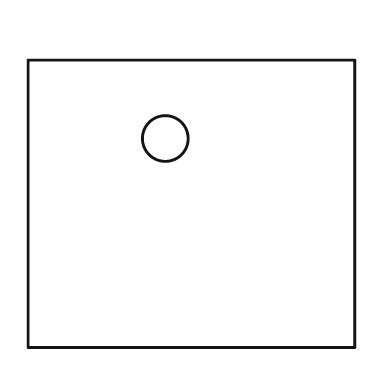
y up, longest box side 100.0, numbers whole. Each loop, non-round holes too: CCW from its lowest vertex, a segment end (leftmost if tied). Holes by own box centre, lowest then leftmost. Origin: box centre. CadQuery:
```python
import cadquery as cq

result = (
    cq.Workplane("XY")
    .moveTo(-50.0, -44.0)
    .lineTo(50.0, -44.0)
    .lineTo(50.0, 44.0)
    .lineTo(-50.0, 44.0)
    .close()
    .moveTo(-8.0, 20.0)
    .circle(7.0)
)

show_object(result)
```